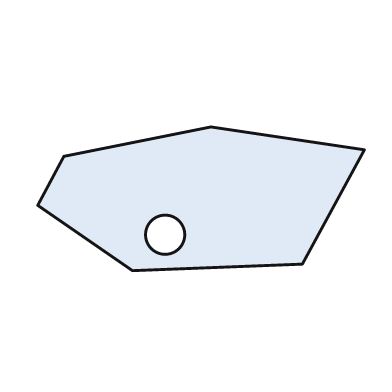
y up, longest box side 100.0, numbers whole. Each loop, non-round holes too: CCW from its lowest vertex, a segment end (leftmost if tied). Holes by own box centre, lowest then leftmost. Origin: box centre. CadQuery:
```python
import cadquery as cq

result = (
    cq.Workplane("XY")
    .moveTo(-21.0, -22.0)
    .lineTo(31.0, -20.0)
    .lineTo(50.0, 15.0)
    .lineTo(3.0, 22.0)
    .lineTo(-42.0, 13.0)
    .lineTo(-50.0, -2.0)
    .close()
    .moveTo(-11.0, -11.0)
    .circle(6.0)
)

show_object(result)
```